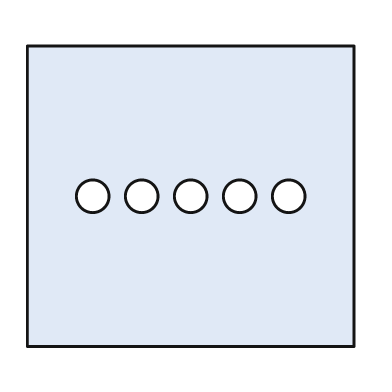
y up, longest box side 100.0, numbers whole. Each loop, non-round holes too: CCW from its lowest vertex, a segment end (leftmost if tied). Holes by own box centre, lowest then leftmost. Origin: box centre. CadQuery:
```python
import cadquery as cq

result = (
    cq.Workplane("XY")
    .moveTo(-50.0, -46.0)
    .lineTo(50.0, -46.0)
    .lineTo(50.0, 46.0)
    .lineTo(-50.0, 46.0)
    .close()
    .moveTo(-30.0, 0.0)
    .circle(5.0)
    .moveTo(-15.0, 0.0)
    .circle(5.0)
    .moveTo(0.0, 0.0)
    .circle(5.0)
    .moveTo(15.0, 0.0)
    .circle(5.0)
    .moveTo(30.0, 0.0)
    .circle(5.0)
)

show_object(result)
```